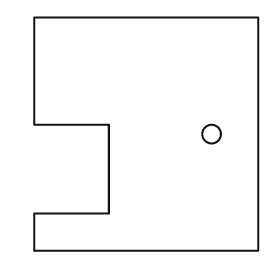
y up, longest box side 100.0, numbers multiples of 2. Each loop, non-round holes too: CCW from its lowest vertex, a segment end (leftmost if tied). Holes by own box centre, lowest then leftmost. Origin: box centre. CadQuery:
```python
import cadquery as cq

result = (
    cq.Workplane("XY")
    .moveTo(-48.0, -50.0)
    .lineTo(48.0, -50.0)
    .lineTo(48.0, 50.0)
    .lineTo(-48.0, 50.0)
    .lineTo(-48.0, 4.0)
    .lineTo(-16.0, 4.0)
    .lineTo(-16.0, -34.0)
    .lineTo(-48.0, -34.0)
    .close()
    .moveTo(28.0, 0.0)
    .circle(4.0)
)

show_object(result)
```